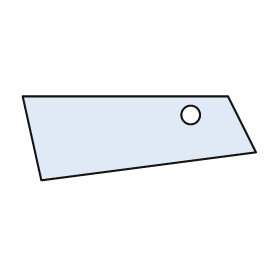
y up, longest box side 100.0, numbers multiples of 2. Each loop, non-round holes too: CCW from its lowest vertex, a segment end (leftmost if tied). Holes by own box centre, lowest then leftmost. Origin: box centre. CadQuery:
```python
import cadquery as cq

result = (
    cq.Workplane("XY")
    .moveTo(-42.0, -18.0)
    .lineTo(50.0, -6.0)
    .lineTo(38.0, 18.0)
    .lineTo(-50.0, 18.0)
    .close()
    .moveTo(22.0, 10.0)
    .circle(4.0)
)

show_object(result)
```